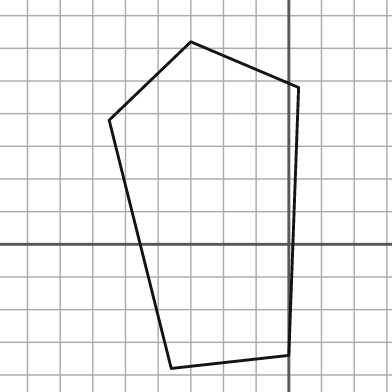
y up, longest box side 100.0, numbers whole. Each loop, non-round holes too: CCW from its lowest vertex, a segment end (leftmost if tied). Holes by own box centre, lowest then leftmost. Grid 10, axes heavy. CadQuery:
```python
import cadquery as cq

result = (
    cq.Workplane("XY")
    .moveTo(-36.0, -38.0)
    .lineTo(0.0, -34.0)
    .lineTo(3.0, 48.0)
    .lineTo(-30.0, 62.0)
    .lineTo(-55.0, 38.0)
    .close()
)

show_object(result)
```